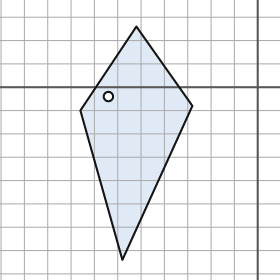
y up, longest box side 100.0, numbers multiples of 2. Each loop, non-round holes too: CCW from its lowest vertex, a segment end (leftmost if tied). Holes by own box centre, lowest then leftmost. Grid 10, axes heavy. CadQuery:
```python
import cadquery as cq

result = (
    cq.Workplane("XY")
    .moveTo(-58.0, -74.0)
    .lineTo(-28.0, -8.0)
    .lineTo(-52.0, 26.0)
    .lineTo(-76.0, -10.0)
    .close()
    .moveTo(-64.0, -4.0)
    .circle(2.0)
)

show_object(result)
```